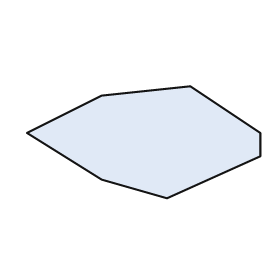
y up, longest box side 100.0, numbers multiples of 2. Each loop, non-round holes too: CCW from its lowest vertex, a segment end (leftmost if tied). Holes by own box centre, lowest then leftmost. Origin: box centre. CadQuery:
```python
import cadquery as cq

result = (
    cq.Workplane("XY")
    .moveTo(10.0, -24.0)
    .lineTo(50.0, -6.0)
    .lineTo(50.0, 4.0)
    .lineTo(20.0, 24.0)
    .lineTo(-18.0, 20.0)
    .lineTo(-50.0, 4.0)
    .lineTo(-18.0, -16.0)
    .close()
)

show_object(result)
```